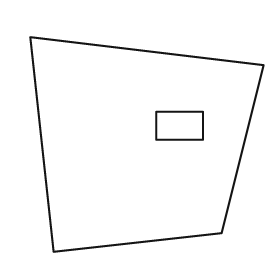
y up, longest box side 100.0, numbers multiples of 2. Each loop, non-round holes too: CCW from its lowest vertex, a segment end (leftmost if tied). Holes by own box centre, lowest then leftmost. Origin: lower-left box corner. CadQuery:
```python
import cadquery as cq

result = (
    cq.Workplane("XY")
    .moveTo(10.0, 0.0)
    .lineTo(82.0, 8.0)
    .lineTo(100.0, 80.0)
    .lineTo(0.0, 92.0)
    .close()
    .moveTo(54.0, 48.0)
    .lineTo(74.0, 48.0)
    .lineTo(74.0, 60.0)
    .lineTo(54.0, 60.0)
    .close()
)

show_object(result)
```